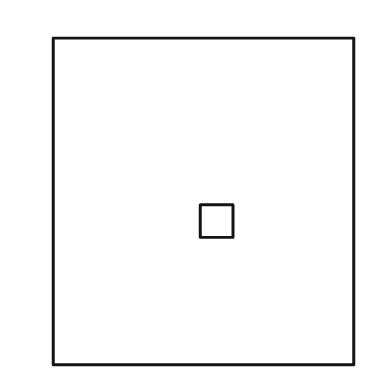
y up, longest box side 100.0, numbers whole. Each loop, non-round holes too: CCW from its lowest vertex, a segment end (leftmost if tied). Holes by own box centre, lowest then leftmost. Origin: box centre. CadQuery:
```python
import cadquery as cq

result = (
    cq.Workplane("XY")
    .moveTo(-46.0, -50.0)
    .lineTo(46.0, -50.0)
    .lineTo(46.0, 50.0)
    .lineTo(-46.0, 50.0)
    .close()
    .moveTo(-1.0, -11.0)
    .lineTo(9.0, -11.0)
    .lineTo(9.0, -1.0)
    .lineTo(-1.0, -1.0)
    .close()
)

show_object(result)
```